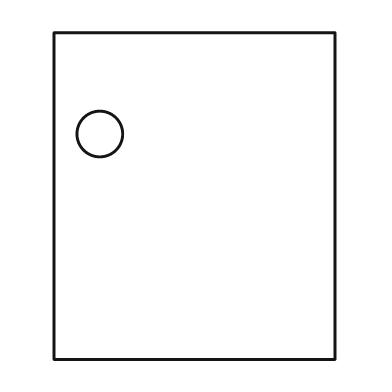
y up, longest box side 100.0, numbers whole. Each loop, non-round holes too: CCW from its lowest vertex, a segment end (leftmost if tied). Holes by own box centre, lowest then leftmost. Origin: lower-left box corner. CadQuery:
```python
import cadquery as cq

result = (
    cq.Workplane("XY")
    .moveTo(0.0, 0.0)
    .lineTo(86.0, 0.0)
    .lineTo(86.0, 100.0)
    .lineTo(0.0, 100.0)
    .close()
    .moveTo(14.0, 69.0)
    .circle(7.0)
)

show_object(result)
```